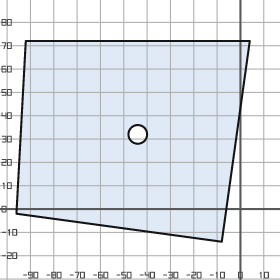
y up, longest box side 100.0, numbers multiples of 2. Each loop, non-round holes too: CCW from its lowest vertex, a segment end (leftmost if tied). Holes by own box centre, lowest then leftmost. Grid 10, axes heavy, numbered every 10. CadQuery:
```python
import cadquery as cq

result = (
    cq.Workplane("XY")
    .moveTo(-8.0, -14.0)
    .lineTo(4.0, 72.0)
    .lineTo(-92.0, 72.0)
    .lineTo(-96.0, -2.0)
    .close()
    .moveTo(-44.0, 32.0)
    .circle(4.0)
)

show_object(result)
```